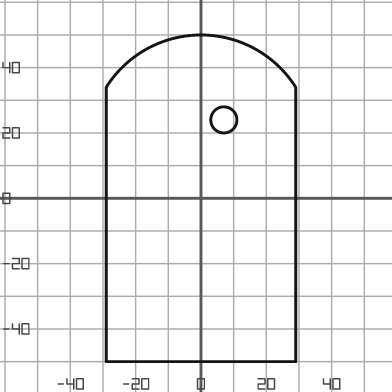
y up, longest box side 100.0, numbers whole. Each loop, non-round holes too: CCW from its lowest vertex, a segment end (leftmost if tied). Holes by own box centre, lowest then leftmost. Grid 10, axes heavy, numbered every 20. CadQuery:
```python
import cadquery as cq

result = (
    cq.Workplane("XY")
    .moveTo(-29.0, -50.0)
    .lineTo(29.0, -50.0)
    .lineTo(29.0, 34.0)
    .threePointArc((0.0, 50.0), (-29.0, 34.0))
    .close()
    .moveTo(7.0, 24.0)
    .circle(4.0)
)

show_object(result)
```